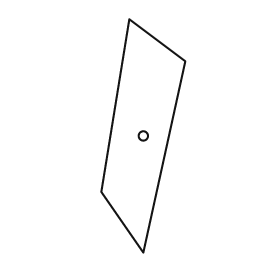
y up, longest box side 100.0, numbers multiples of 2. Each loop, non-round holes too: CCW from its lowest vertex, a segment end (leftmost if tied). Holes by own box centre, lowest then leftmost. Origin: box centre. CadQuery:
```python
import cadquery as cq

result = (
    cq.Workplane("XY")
    .moveTo(0.0, -50.0)
    .lineTo(18.0, 32.0)
    .lineTo(-6.0, 50.0)
    .lineTo(-18.0, -24.0)
    .close()
    .moveTo(0.0, 0.0)
    .circle(2.0)
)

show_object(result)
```